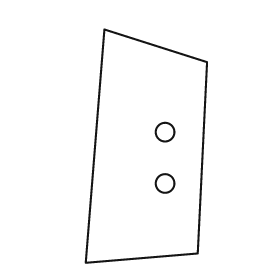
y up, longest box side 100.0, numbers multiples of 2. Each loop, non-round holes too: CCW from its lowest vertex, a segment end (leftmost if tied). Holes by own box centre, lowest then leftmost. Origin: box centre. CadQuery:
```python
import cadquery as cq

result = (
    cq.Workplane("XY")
    .moveTo(-26.0, -50.0)
    .lineTo(22.0, -46.0)
    .lineTo(26.0, 36.0)
    .lineTo(-18.0, 50.0)
    .close()
    .moveTo(8.0, -16.0)
    .circle(4.0)
    .moveTo(8.0, 6.0)
    .circle(4.0)
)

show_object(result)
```